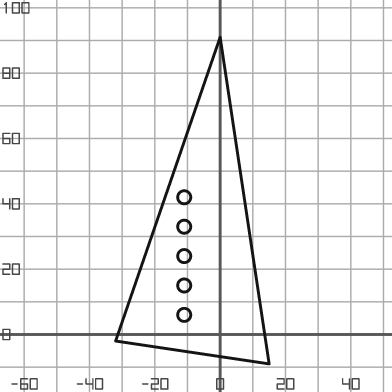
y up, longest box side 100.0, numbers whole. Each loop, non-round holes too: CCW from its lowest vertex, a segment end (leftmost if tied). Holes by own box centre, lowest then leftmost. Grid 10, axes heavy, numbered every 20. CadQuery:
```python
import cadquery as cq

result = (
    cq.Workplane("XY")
    .moveTo(15.0, -9.0)
    .lineTo(0.0, 91.0)
    .lineTo(-32.0, -2.0)
    .close()
    .moveTo(-11.0, 6.0)
    .circle(2.0)
    .moveTo(-11.0, 15.0)
    .circle(2.0)
    .moveTo(-11.0, 24.0)
    .circle(2.0)
    .moveTo(-11.0, 33.0)
    .circle(2.0)
    .moveTo(-11.0, 42.0)
    .circle(2.0)
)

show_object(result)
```